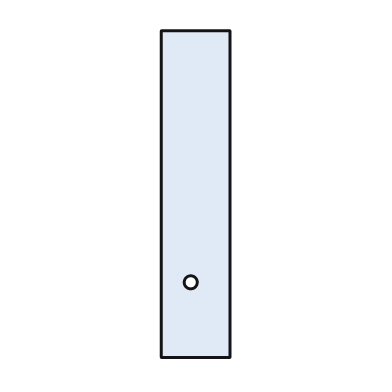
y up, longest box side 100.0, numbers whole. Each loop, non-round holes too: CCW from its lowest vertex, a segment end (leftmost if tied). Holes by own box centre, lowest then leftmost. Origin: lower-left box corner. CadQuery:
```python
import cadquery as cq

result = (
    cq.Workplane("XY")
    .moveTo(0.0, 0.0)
    .lineTo(21.0, 0.0)
    .lineTo(21.0, 100.0)
    .lineTo(0.0, 100.0)
    .close()
    .moveTo(9.0, 23.0)
    .circle(2.0)
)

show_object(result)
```